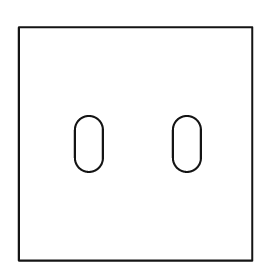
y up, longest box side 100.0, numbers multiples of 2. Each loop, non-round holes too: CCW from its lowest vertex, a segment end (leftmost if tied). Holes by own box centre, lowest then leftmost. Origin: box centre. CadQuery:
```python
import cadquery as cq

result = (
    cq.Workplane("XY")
    .moveTo(-50.0, -50.0)
    .lineTo(50.0, -50.0)
    .lineTo(50.0, 50.0)
    .lineTo(-50.0, 50.0)
    .close()
    .moveTo(-26.0, -6.0)
    .threePointArc((-20.0, -12.0), (-14.0, -6.0))
    .lineTo(-14.0, 6.0)
    .threePointArc((-20.0, 12.0), (-26.0, 6.0))
    .close()
    .moveTo(16.0, -6.0)
    .threePointArc((22.0, -12.0), (28.0, -6.0))
    .lineTo(28.0, 6.0)
    .threePointArc((22.0, 12.0), (16.0, 6.0))
    .close()
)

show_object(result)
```